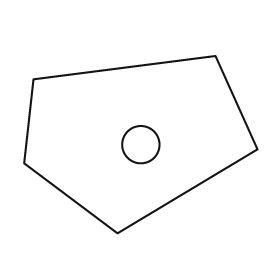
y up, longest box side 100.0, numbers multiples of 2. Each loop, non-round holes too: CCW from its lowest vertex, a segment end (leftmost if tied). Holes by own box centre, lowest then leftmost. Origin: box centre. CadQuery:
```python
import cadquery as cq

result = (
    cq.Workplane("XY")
    .moveTo(-10.0, -38.0)
    .lineTo(50.0, -2.0)
    .lineTo(32.0, 38.0)
    .lineTo(-46.0, 28.0)
    .lineTo(-50.0, -8.0)
    .close()
    .moveTo(0.0, 0.0)
    .circle(8.0)
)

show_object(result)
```